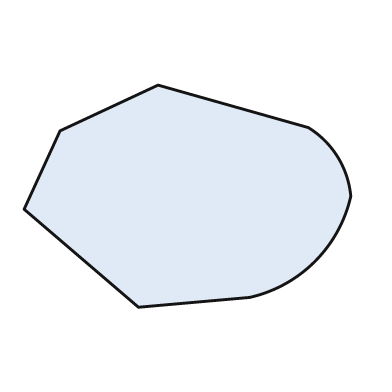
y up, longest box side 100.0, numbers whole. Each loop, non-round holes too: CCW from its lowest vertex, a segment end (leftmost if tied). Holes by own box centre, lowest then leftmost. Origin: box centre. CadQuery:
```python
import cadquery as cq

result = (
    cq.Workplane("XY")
    .moveTo(-15.0, -34.0)
    .lineTo(19.0, -31.0)
    .threePointArc((39.0, -20.0), (50.0, 0.0))
    .threePointArc((46.0, 12.0), (37.0, 21.0))
    .lineTo(-9.0, 34.0)
    .lineTo(-39.0, 20.0)
    .lineTo(-50.0, -4.0)
    .close()
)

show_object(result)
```